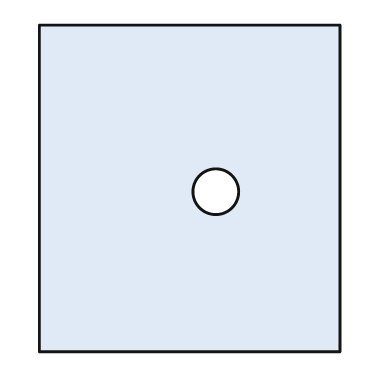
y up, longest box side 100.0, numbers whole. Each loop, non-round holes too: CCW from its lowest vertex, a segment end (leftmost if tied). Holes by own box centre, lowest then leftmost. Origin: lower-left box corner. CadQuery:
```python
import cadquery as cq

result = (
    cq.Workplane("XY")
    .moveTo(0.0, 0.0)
    .lineTo(92.0, 0.0)
    .lineTo(92.0, 100.0)
    .lineTo(0.0, 100.0)
    .close()
    .moveTo(54.0, 49.0)
    .circle(7.0)
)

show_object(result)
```